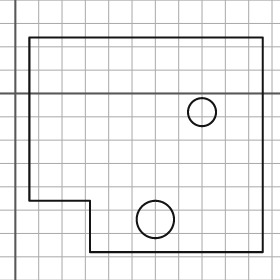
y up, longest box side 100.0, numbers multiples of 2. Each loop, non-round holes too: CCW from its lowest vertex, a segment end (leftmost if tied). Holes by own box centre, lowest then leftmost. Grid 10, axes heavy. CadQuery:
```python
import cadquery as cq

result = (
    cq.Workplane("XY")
    .moveTo(32.0, -68.0)
    .lineTo(106.0, -68.0)
    .lineTo(106.0, 24.0)
    .lineTo(6.0, 24.0)
    .lineTo(6.0, -46.0)
    .lineTo(32.0, -46.0)
    .close()
    .moveTo(60.0, -54.0)
    .circle(8.0)
    .moveTo(80.0, -8.0)
    .circle(6.0)
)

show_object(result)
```